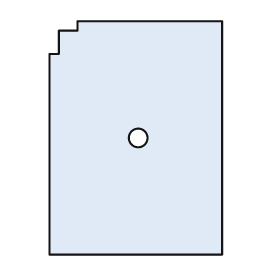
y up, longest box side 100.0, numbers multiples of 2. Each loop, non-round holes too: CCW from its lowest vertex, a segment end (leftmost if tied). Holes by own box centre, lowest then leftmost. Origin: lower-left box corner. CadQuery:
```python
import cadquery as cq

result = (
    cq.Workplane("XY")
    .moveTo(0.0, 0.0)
    .lineTo(74.0, 0.0)
    .lineTo(74.0, 100.0)
    .lineTo(12.0, 100.0)
    .lineTo(12.0, 96.0)
    .lineTo(4.0, 96.0)
    .lineTo(4.0, 86.0)
    .lineTo(0.0, 86.0)
    .close()
    .moveTo(38.0, 50.0)
    .circle(4.0)
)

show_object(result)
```